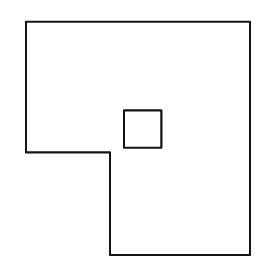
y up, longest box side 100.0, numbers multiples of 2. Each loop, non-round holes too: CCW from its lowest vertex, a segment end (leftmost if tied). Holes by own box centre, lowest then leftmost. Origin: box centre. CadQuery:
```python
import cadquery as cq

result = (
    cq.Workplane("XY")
    .moveTo(-12.0, -50.0)
    .lineTo(48.0, -50.0)
    .lineTo(48.0, 50.0)
    .lineTo(-48.0, 50.0)
    .lineTo(-48.0, -6.0)
    .lineTo(-12.0, -6.0)
    .close()
    .moveTo(-6.0, -4.0)
    .lineTo(10.0, -4.0)
    .lineTo(10.0, 12.0)
    .lineTo(-6.0, 12.0)
    .close()
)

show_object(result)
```